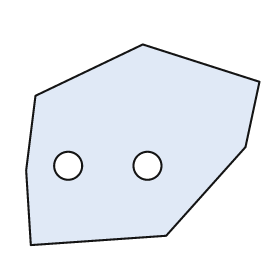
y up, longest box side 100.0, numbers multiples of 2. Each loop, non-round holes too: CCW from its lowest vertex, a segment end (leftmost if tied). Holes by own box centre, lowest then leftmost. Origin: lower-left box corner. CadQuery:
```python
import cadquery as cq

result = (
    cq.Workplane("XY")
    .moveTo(2.0, 0.0)
    .lineTo(60.0, 4.0)
    .lineTo(94.0, 42.0)
    .lineTo(100.0, 70.0)
    .lineTo(50.0, 86.0)
    .lineTo(4.0, 64.0)
    .lineTo(0.0, 32.0)
    .close()
    .moveTo(18.0, 34.0)
    .circle(6.0)
    .moveTo(52.0, 34.0)
    .circle(6.0)
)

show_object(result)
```